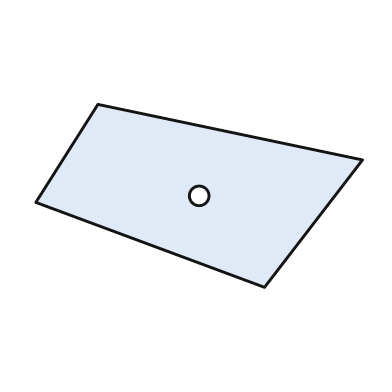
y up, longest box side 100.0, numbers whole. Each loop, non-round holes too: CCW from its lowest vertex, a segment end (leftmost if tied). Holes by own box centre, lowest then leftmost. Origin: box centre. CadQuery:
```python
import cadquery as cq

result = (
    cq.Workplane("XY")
    .moveTo(20.0, -28.0)
    .lineTo(50.0, 11.0)
    .lineTo(-31.0, 28.0)
    .lineTo(-50.0, -2.0)
    .close()
    .moveTo(0.0, 0.0)
    .circle(3.0)
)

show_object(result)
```